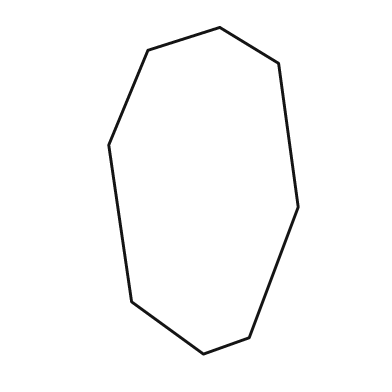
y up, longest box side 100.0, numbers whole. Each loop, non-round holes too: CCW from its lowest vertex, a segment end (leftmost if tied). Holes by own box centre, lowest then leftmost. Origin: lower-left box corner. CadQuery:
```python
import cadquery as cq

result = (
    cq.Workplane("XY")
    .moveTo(29.0, 0.0)
    .lineTo(43.0, 5.0)
    .lineTo(58.0, 45.0)
    .lineTo(52.0, 89.0)
    .lineTo(34.0, 100.0)
    .lineTo(12.0, 93.0)
    .lineTo(0.0, 64.0)
    .lineTo(7.0, 16.0)
    .close()
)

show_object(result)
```